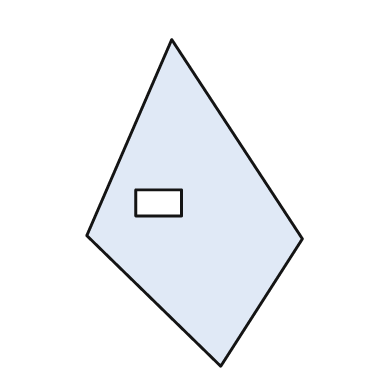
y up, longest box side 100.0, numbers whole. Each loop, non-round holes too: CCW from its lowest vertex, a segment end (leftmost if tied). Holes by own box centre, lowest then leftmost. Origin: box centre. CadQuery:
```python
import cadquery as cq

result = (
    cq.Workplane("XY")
    .moveTo(8.0, -50.0)
    .lineTo(33.0, -11.0)
    .lineTo(-7.0, 50.0)
    .lineTo(-33.0, -10.0)
    .close()
    .moveTo(-18.0, -4.0)
    .lineTo(-4.0, -4.0)
    .lineTo(-4.0, 4.0)
    .lineTo(-18.0, 4.0)
    .close()
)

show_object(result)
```